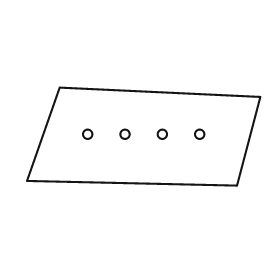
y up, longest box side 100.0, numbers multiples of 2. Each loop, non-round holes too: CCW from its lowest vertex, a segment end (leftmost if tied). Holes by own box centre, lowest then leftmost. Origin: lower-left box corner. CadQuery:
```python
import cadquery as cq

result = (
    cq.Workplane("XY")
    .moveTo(90.0, 0.0)
    .lineTo(100.0, 38.0)
    .lineTo(14.0, 42.0)
    .lineTo(0.0, 2.0)
    .close()
    .moveTo(26.0, 22.0)
    .circle(2.0)
    .moveTo(42.0, 22.0)
    .circle(2.0)
    .moveTo(58.0, 22.0)
    .circle(2.0)
    .moveTo(74.0, 22.0)
    .circle(2.0)
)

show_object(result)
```